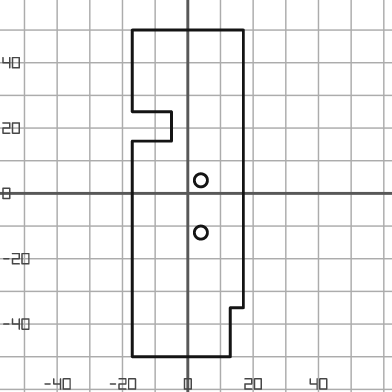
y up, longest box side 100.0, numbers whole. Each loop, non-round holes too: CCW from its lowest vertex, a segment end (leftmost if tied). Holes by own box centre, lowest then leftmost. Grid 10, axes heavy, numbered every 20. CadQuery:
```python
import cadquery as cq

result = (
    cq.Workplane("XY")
    .moveTo(-17.0, -50.0)
    .lineTo(13.0, -50.0)
    .lineTo(13.0, -35.0)
    .lineTo(17.0, -35.0)
    .lineTo(17.0, 50.0)
    .lineTo(-17.0, 50.0)
    .lineTo(-17.0, 25.0)
    .lineTo(-5.0, 25.0)
    .lineTo(-5.0, 16.0)
    .lineTo(-17.0, 16.0)
    .close()
    .moveTo(4.0, -12.0)
    .circle(2.0)
    .moveTo(4.0, 4.0)
    .circle(2.0)
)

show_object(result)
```